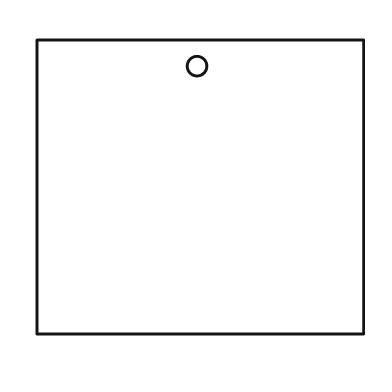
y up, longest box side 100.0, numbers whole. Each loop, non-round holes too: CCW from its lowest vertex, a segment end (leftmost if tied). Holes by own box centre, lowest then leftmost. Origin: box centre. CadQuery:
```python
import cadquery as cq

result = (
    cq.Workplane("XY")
    .moveTo(-50.0, -45.0)
    .lineTo(50.0, -45.0)
    .lineTo(50.0, 45.0)
    .lineTo(-50.0, 45.0)
    .close()
    .moveTo(-1.0, 37.0)
    .circle(3.0)
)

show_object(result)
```